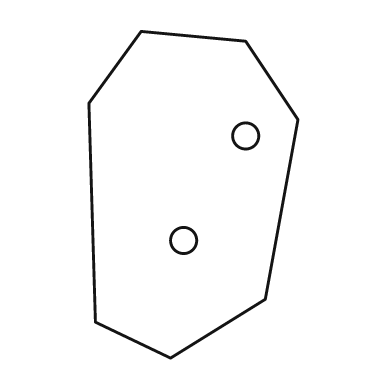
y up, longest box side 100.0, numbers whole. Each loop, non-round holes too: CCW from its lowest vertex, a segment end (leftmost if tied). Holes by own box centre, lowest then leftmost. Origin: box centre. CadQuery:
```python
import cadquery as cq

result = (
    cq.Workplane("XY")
    .moveTo(-7.0, -50.0)
    .lineTo(22.0, -32.0)
    .lineTo(32.0, 23.0)
    .lineTo(16.0, 47.0)
    .lineTo(-16.0, 50.0)
    .lineTo(-32.0, 28.0)
    .lineTo(-30.0, -39.0)
    .close()
    .moveTo(-3.0, -14.0)
    .circle(4.0)
    .moveTo(16.0, 18.0)
    .circle(4.0)
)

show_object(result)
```